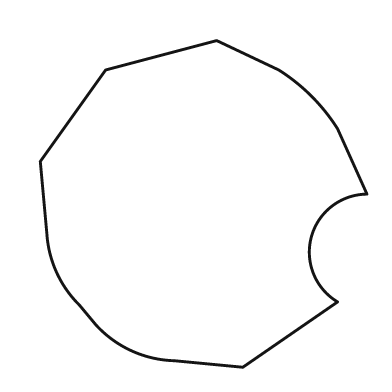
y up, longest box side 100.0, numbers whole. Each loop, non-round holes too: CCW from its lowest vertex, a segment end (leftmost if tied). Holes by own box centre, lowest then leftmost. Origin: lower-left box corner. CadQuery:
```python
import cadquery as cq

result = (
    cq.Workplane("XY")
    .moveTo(62.0, 0.0)
    .lineTo(91.0, 20.0)
    .threePointArc((83.0, 40.0), (100.0, 53.0))
    .lineTo(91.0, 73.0)
    .threePointArc((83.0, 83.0), (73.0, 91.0))
    .lineTo(54.0, 100.0)
    .lineTo(20.0, 91.0)
    .lineTo(0.0, 63.0)
    .lineTo(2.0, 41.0)
    .threePointArc((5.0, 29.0), (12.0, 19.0))
    .lineTo(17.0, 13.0)
    .threePointArc((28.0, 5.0), (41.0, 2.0))
    .close()
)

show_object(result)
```